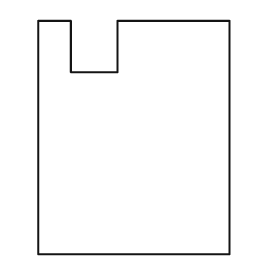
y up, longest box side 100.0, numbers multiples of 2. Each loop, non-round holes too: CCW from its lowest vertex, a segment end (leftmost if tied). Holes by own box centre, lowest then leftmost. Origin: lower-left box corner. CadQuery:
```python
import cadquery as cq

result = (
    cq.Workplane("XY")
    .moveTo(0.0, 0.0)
    .lineTo(82.0, 0.0)
    .lineTo(82.0, 100.0)
    .lineTo(34.0, 100.0)
    .lineTo(34.0, 78.0)
    .lineTo(14.0, 78.0)
    .lineTo(14.0, 100.0)
    .lineTo(0.0, 100.0)
    .close()
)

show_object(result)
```